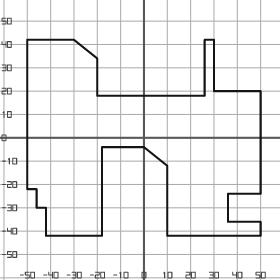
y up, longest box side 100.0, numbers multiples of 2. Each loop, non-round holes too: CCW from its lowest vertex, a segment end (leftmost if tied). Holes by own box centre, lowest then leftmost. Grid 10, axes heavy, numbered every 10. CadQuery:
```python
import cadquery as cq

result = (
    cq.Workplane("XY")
    .moveTo(-42.0, -42.0)
    .lineTo(-18.0, -42.0)
    .lineTo(-18.0, -4.0)
    .lineTo(0.0, -4.0)
    .lineTo(10.0, -12.0)
    .lineTo(10.0, -42.0)
    .lineTo(50.0, -42.0)
    .lineTo(50.0, -36.0)
    .lineTo(36.0, -36.0)
    .lineTo(36.0, -24.0)
    .lineTo(50.0, -24.0)
    .lineTo(50.0, 20.0)
    .lineTo(30.0, 20.0)
    .lineTo(30.0, 42.0)
    .lineTo(26.0, 42.0)
    .lineTo(26.0, 18.0)
    .lineTo(-20.0, 18.0)
    .lineTo(-20.0, 34.0)
    .lineTo(-30.0, 42.0)
    .lineTo(-50.0, 42.0)
    .lineTo(-50.0, -22.0)
    .lineTo(-46.0, -22.0)
    .lineTo(-46.0, -30.0)
    .lineTo(-42.0, -30.0)
    .close()
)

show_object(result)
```